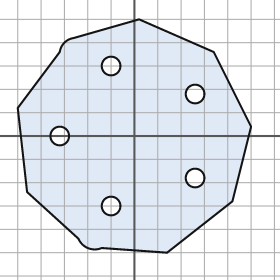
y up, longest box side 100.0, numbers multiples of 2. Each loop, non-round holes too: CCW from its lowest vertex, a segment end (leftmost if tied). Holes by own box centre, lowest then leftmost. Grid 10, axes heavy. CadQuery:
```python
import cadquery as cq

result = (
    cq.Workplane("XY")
    .moveTo(14.0, -50.0)
    .lineTo(42.0, -28.0)
    .lineTo(50.0, 4.0)
    .lineTo(34.0, 36.0)
    .lineTo(2.0, 50.0)
    .lineTo(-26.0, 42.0)
    .threePointArc((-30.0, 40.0), (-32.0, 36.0))
    .lineTo(-50.0, 12.0)
    .lineTo(-46.0, -24.0)
    .lineTo(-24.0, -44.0)
    .threePointArc((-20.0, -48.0), (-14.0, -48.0))
    .close()
    .moveTo(-10.0, -30.0)
    .circle(4.0)
    .moveTo(26.0, -18.0)
    .circle(4.0)
    .moveTo(-32.0, 0.0)
    .circle(4.0)
    .moveTo(26.0, 18.0)
    .circle(4.0)
    .moveTo(-10.0, 30.0)
    .circle(4.0)
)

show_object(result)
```